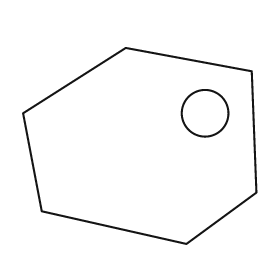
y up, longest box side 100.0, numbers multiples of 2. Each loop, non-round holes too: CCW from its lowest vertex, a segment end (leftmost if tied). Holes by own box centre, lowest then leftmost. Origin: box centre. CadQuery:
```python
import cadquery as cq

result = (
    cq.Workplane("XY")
    .moveTo(20.0, -42.0)
    .lineTo(50.0, -20.0)
    .lineTo(48.0, 32.0)
    .lineTo(-6.0, 42.0)
    .lineTo(-50.0, 14.0)
    .lineTo(-42.0, -28.0)
    .close()
    .moveTo(28.0, 14.0)
    .circle(10.0)
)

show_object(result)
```